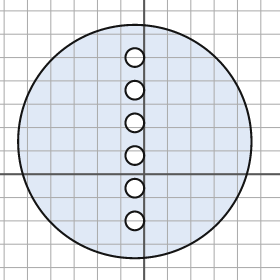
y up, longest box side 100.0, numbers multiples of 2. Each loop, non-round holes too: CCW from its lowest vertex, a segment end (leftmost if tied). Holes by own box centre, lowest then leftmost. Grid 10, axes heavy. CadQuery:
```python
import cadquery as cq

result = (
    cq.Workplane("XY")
    .moveTo(-4.0, 14.0)
    .circle(50.0)
    .moveTo(-4.0, -20.0)
    .circle(4.0)
    .moveTo(-4.0, -6.0)
    .circle(4.0)
    .moveTo(-4.0, 8.0)
    .circle(4.0)
    .moveTo(-4.0, 22.0)
    .circle(4.0)
    .moveTo(-4.0, 36.0)
    .circle(4.0)
    .moveTo(-4.0, 50.0)
    .circle(4.0)
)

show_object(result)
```